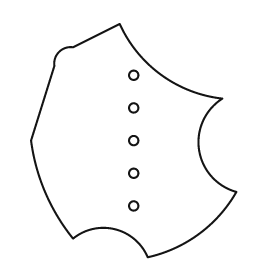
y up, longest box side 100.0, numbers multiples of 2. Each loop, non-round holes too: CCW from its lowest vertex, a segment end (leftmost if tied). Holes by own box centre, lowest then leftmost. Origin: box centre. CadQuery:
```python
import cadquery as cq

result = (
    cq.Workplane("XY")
    .moveTo(6.0, -50.0)
    .threePointArc((28.0, -40.0), (44.0, -22.0))
    .threePointArc((28.0, -4.0), (38.0, 18.0))
    .threePointArc((12.0, 28.0), (-6.0, 50.0))
    .lineTo(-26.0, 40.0)
    .threePointArc((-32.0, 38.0), (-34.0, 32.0))
    .lineTo(-44.0, 0.0)
    .threePointArc((-38.0, -22.0), (-26.0, -42.0))
    .threePointArc((-8.0, -38.0), (6.0, -50.0))
    .close()
    .moveTo(0.0, -28.0)
    .circle(2.0)
    .moveTo(0.0, -14.0)
    .circle(2.0)
    .moveTo(0.0, 0.0)
    .circle(2.0)
    .moveTo(0.0, 14.0)
    .circle(2.0)
    .moveTo(0.0, 28.0)
    .circle(2.0)
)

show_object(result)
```